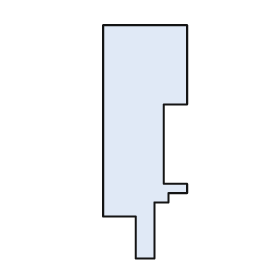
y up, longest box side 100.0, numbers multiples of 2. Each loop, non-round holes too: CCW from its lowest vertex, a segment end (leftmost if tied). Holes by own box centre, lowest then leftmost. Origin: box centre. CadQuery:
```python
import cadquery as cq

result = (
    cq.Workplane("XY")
    .moveTo(-4.0, -50.0)
    .lineTo(4.0, -50.0)
    .lineTo(4.0, -26.0)
    .lineTo(10.0, -26.0)
    .lineTo(10.0, -22.0)
    .lineTo(18.0, -22.0)
    .lineTo(18.0, -18.0)
    .lineTo(8.0, -18.0)
    .lineTo(8.0, 16.0)
    .lineTo(18.0, 16.0)
    .lineTo(18.0, 50.0)
    .lineTo(-18.0, 50.0)
    .lineTo(-18.0, -32.0)
    .lineTo(-4.0, -32.0)
    .close()
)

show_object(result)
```